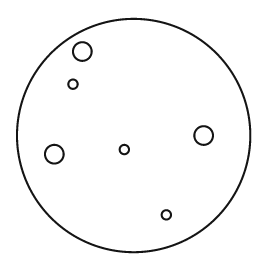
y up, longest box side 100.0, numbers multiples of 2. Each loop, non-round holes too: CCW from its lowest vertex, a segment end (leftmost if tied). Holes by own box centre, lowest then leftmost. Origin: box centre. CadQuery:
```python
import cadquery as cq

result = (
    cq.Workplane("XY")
    .moveTo(0.0, 0.0)
    .circle(50.0)
    .moveTo(14.0, -34.0)
    .circle(2.0)
    .moveTo(-34.0, -8.0)
    .circle(4.0)
    .moveTo(-4.0, -6.0)
    .circle(2.0)
    .moveTo(30.0, 0.0)
    .circle(4.0)
    .moveTo(-26.0, 22.0)
    .circle(2.0)
    .moveTo(-22.0, 36.0)
    .circle(4.0)
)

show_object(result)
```